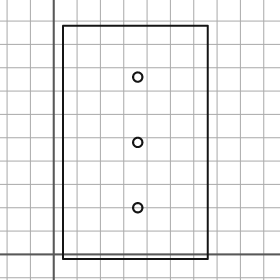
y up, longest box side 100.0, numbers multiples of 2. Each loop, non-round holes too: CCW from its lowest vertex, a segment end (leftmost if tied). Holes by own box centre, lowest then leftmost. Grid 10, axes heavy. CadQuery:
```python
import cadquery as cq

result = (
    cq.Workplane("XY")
    .moveTo(4.0, -2.0)
    .lineTo(66.0, -2.0)
    .lineTo(66.0, 98.0)
    .lineTo(4.0, 98.0)
    .close()
    .moveTo(36.0, 20.0)
    .circle(2.0)
    .moveTo(36.0, 48.0)
    .circle(2.0)
    .moveTo(36.0, 76.0)
    .circle(2.0)
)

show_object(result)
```